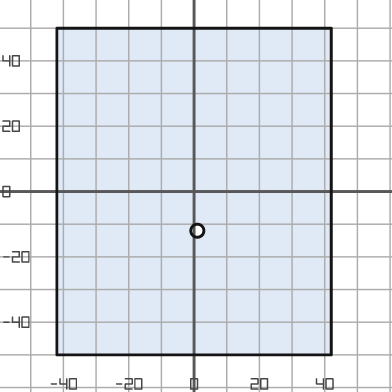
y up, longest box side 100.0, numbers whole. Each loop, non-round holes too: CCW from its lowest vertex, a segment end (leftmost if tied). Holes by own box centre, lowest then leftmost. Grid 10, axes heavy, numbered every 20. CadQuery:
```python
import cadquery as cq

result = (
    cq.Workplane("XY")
    .moveTo(-42.0, -50.0)
    .lineTo(42.0, -50.0)
    .lineTo(42.0, 50.0)
    .lineTo(-42.0, 50.0)
    .close()
    .moveTo(1.0, -12.0)
    .circle(2.0)
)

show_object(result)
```